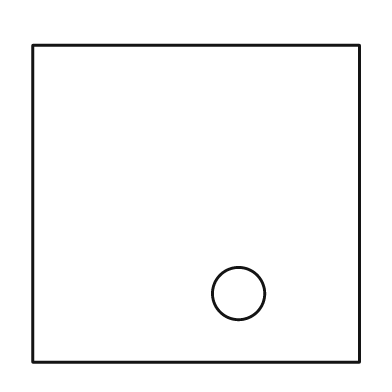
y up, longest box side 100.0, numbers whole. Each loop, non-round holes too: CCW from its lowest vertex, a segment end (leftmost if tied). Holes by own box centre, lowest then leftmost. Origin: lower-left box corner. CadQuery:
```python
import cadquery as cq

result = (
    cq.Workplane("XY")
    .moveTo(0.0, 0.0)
    .lineTo(100.0, 0.0)
    .lineTo(100.0, 97.0)
    .lineTo(0.0, 97.0)
    .close()
    .moveTo(63.0, 21.0)
    .circle(8.0)
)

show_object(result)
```